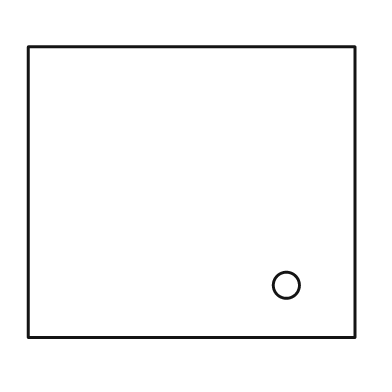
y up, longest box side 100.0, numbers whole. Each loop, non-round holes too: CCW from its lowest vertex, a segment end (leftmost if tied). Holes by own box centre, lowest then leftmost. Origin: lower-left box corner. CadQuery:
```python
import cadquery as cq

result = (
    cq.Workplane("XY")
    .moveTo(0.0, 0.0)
    .lineTo(100.0, 0.0)
    .lineTo(100.0, 89.0)
    .lineTo(0.0, 89.0)
    .close()
    .moveTo(79.0, 16.0)
    .circle(4.0)
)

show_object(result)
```